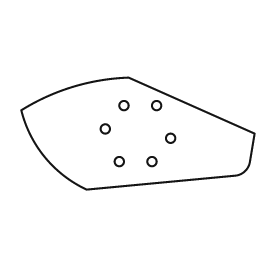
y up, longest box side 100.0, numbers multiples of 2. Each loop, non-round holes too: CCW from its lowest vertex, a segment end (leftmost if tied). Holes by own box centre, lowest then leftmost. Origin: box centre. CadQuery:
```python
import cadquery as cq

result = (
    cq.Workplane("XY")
    .moveTo(-22.0, -24.0)
    .lineTo(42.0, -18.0)
    .threePointArc((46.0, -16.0), (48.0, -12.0))
    .lineTo(50.0, 0.0)
    .lineTo(-4.0, 24.0)
    .threePointArc((-28.0, 20.0), (-50.0, 10.0))
    .threePointArc((-40.0, -10.0), (-22.0, -24.0))
    .close()
    .moveTo(-8.0, -12.0)
    .circle(2.0)
    .moveTo(6.0, -12.0)
    .circle(2.0)
    .moveTo(14.0, -2.0)
    .circle(2.0)
    .moveTo(-14.0, 2.0)
    .circle(2.0)
    .moveTo(-6.0, 12.0)
    .circle(2.0)
    .moveTo(8.0, 12.0)
    .circle(2.0)
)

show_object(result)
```